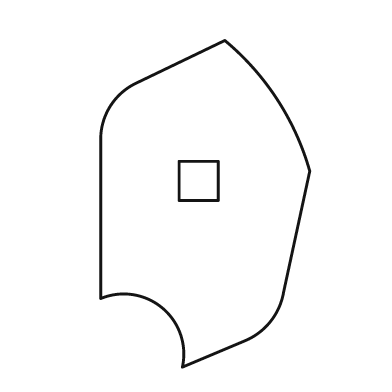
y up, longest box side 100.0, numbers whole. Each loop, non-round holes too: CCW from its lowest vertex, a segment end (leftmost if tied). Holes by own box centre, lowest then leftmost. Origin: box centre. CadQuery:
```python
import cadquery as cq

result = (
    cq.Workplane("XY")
    .moveTo(-7.0, -50.0)
    .lineTo(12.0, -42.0)
    .threePointArc((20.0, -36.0), (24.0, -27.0))
    .lineTo(32.0, 10.0)
    .threePointArc((22.0, 32.0), (6.0, 50.0))
    .lineTo(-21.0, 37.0)
    .threePointArc((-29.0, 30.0), (-32.0, 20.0))
    .lineTo(-32.0, -29.0)
    .threePointArc((-13.0, -32.0), (-7.0, -50.0))
    .close()
    .moveTo(-8.0, 1.0)
    .lineTo(4.0, 1.0)
    .lineTo(4.0, 13.0)
    .lineTo(-8.0, 13.0)
    .close()
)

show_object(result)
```